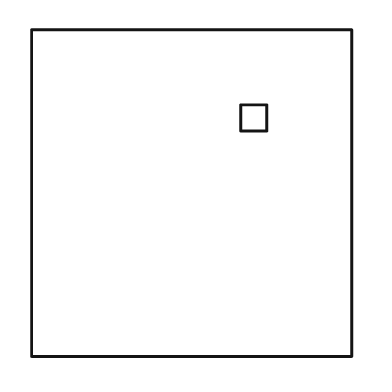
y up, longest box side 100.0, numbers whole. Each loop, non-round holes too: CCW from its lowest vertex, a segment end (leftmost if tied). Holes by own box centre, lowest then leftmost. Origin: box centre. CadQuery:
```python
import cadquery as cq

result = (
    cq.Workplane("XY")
    .moveTo(-49.0, -50.0)
    .lineTo(49.0, -50.0)
    .lineTo(49.0, 50.0)
    .lineTo(-49.0, 50.0)
    .close()
    .moveTo(15.0, 19.0)
    .lineTo(23.0, 19.0)
    .lineTo(23.0, 27.0)
    .lineTo(15.0, 27.0)
    .close()
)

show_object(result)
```